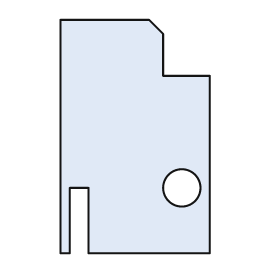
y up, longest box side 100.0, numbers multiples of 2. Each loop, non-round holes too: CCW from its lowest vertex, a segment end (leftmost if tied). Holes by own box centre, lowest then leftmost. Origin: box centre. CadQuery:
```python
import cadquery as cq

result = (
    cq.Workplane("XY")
    .moveTo(-32.0, -50.0)
    .lineTo(-28.0, -50.0)
    .lineTo(-28.0, -22.0)
    .lineTo(-20.0, -22.0)
    .lineTo(-20.0, -50.0)
    .lineTo(32.0, -50.0)
    .lineTo(32.0, 26.0)
    .lineTo(12.0, 26.0)
    .lineTo(12.0, 44.0)
    .lineTo(6.0, 50.0)
    .lineTo(-32.0, 50.0)
    .close()
    .moveTo(20.0, -22.0)
    .circle(8.0)
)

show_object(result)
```